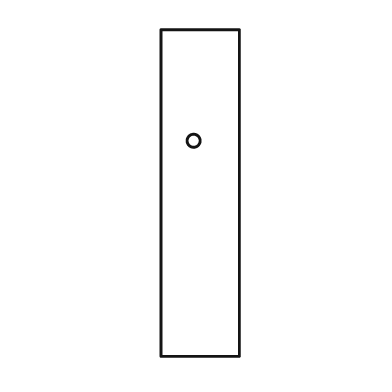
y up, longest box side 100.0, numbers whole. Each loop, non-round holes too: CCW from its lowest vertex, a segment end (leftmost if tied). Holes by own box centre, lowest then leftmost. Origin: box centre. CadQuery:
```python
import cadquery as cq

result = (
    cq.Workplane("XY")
    .moveTo(-12.0, -50.0)
    .lineTo(12.0, -50.0)
    .lineTo(12.0, 50.0)
    .lineTo(-12.0, 50.0)
    .close()
    .moveTo(-2.0, 16.0)
    .circle(2.0)
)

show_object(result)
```